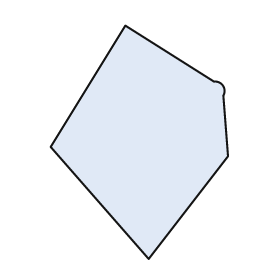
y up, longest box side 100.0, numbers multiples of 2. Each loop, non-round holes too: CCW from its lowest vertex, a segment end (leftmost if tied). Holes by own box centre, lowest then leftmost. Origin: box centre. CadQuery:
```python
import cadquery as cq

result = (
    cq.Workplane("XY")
    .moveTo(4.0, -50.0)
    .lineTo(38.0, -6.0)
    .lineTo(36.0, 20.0)
    .threePointArc((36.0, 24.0), (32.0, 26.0))
    .lineTo(-6.0, 50.0)
    .lineTo(-38.0, -2.0)
    .close()
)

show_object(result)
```